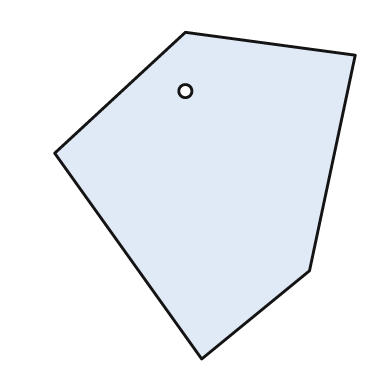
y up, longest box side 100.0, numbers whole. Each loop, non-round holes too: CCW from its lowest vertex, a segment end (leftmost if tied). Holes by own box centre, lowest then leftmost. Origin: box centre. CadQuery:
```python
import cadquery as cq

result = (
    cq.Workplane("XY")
    .moveTo(-1.0, -50.0)
    .lineTo(32.0, -23.0)
    .lineTo(46.0, 43.0)
    .lineTo(-6.0, 50.0)
    .lineTo(-46.0, 13.0)
    .close()
    .moveTo(-6.0, 32.0)
    .circle(2.0)
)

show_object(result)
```